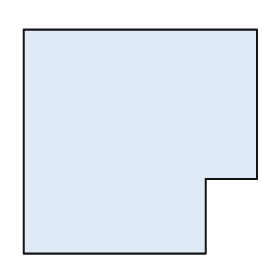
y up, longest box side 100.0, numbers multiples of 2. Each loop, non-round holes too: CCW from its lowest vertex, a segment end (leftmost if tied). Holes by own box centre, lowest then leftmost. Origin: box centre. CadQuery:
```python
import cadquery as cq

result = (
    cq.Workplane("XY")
    .moveTo(-50.0, -48.0)
    .lineTo(28.0, -48.0)
    .lineTo(28.0, -16.0)
    .lineTo(50.0, -16.0)
    .lineTo(50.0, 48.0)
    .lineTo(-50.0, 48.0)
    .close()
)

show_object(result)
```